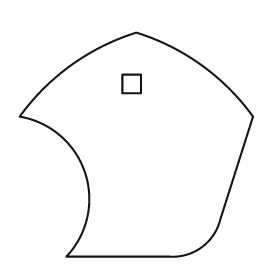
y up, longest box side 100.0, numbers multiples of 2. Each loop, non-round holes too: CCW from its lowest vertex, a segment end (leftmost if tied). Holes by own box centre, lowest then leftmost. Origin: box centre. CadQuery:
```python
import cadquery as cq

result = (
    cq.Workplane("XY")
    .moveTo(-30.0, -48.0)
    .lineTo(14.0, -48.0)
    .threePointArc((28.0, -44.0), (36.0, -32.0))
    .lineTo(50.0, 12.0)
    .threePointArc((28.0, 34.0), (0.0, 48.0))
    .threePointArc((-28.0, 34.0), (-50.0, 12.0))
    .threePointArc((-22.0, -12.0), (-30.0, -48.0))
    .close()
    .moveTo(-6.0, 22.0)
    .lineTo(2.0, 22.0)
    .lineTo(2.0, 30.0)
    .lineTo(-6.0, 30.0)
    .close()
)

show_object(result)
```